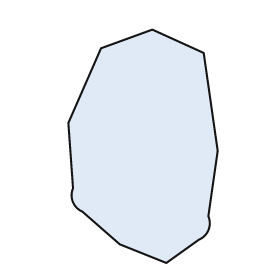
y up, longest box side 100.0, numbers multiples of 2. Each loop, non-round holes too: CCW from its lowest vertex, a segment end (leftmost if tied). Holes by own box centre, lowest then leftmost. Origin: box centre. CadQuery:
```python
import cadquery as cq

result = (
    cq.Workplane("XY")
    .moveTo(10.0, -50.0)
    .lineTo(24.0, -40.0)
    .threePointArc((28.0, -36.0), (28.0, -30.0))
    .lineTo(32.0, -2.0)
    .lineTo(26.0, 40.0)
    .lineTo(4.0, 50.0)
    .lineTo(-18.0, 42.0)
    .lineTo(-32.0, 10.0)
    .lineTo(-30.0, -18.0)
    .threePointArc((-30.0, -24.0), (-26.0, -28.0))
    .lineTo(-10.0, -42.0)
    .close()
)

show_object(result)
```